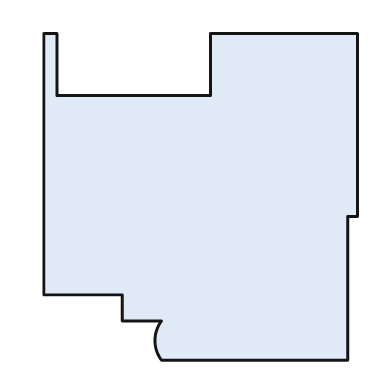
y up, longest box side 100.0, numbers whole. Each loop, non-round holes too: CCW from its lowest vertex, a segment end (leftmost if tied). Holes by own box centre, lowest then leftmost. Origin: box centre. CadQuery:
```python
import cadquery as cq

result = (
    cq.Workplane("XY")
    .moveTo(-12.0, -50.0)
    .lineTo(45.0, -50.0)
    .lineTo(45.0, -6.0)
    .lineTo(48.0, -6.0)
    .lineTo(48.0, 50.0)
    .lineTo(3.0, 50.0)
    .lineTo(3.0, 31.0)
    .lineTo(-44.0, 31.0)
    .lineTo(-44.0, 50.0)
    .lineTo(-48.0, 50.0)
    .lineTo(-48.0, -30.0)
    .lineTo(-24.0, -30.0)
    .lineTo(-24.0, -38.0)
    .lineTo(-12.0, -38.0)
    .threePointArc((-14.0, -44.0), (-12.0, -50.0))
    .close()
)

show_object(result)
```